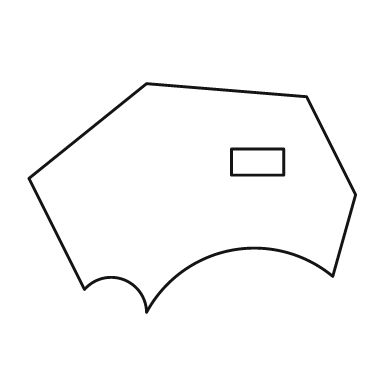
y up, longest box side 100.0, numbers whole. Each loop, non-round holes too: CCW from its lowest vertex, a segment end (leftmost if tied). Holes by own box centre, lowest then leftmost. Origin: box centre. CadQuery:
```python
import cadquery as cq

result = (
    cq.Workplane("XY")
    .moveTo(-14.0, -35.0)
    .threePointArc((12.0, -16.0), (43.0, -24.0))
    .lineTo(50.0, 1.0)
    .lineTo(35.0, 31.0)
    .lineTo(-14.0, 35.0)
    .lineTo(-50.0, 6.0)
    .lineTo(-33.0, -28.0)
    .threePointArc((-21.0, -25.0), (-14.0, -35.0))
    .close()
    .moveTo(12.0, 7.0)
    .lineTo(28.0, 7.0)
    .lineTo(28.0, 15.0)
    .lineTo(12.0, 15.0)
    .close()
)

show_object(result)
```